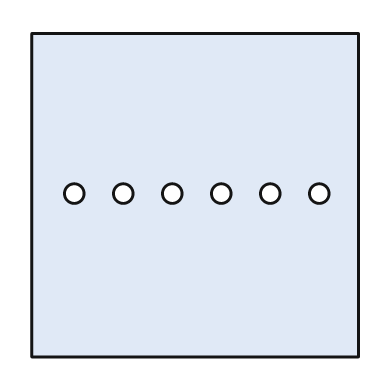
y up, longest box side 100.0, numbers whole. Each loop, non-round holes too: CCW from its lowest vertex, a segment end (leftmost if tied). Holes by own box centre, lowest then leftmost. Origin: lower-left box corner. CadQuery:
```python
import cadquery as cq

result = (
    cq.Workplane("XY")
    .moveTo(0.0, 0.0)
    .lineTo(100.0, 0.0)
    .lineTo(100.0, 99.0)
    .lineTo(0.0, 99.0)
    .close()
    .moveTo(13.0, 50.0)
    .circle(3.0)
    .moveTo(28.0, 50.0)
    .circle(3.0)
    .moveTo(43.0, 50.0)
    .circle(3.0)
    .moveTo(58.0, 50.0)
    .circle(3.0)
    .moveTo(73.0, 50.0)
    .circle(3.0)
    .moveTo(88.0, 50.0)
    .circle(3.0)
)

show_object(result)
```